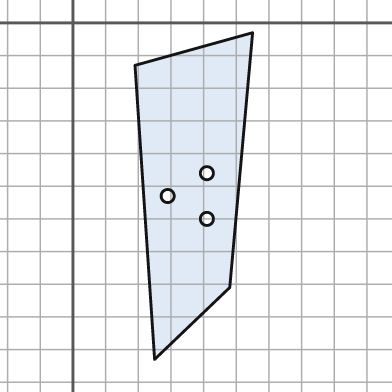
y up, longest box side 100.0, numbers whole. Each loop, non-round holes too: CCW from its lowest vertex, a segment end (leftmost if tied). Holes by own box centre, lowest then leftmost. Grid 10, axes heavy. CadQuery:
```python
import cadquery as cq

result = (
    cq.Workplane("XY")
    .moveTo(25.0, -103.0)
    .lineTo(48.0, -81.0)
    .lineTo(55.0, -3.0)
    .lineTo(19.0, -13.0)
    .close()
    .moveTo(41.0, -60.0)
    .circle(2.0)
    .moveTo(29.0, -53.0)
    .circle(2.0)
    .moveTo(41.0, -46.0)
    .circle(2.0)
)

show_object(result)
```